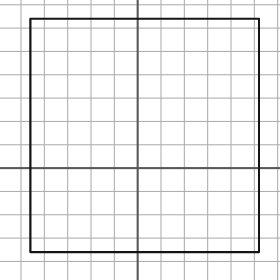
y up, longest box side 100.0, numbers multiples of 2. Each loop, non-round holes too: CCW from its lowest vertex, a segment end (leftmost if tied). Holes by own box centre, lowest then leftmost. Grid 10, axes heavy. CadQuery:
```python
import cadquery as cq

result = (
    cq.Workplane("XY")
    .moveTo(-46.0, -36.0)
    .lineTo(52.0, -36.0)
    .lineTo(52.0, 64.0)
    .lineTo(-46.0, 64.0)
    .close()
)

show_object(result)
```